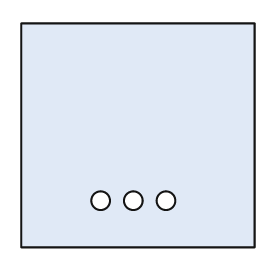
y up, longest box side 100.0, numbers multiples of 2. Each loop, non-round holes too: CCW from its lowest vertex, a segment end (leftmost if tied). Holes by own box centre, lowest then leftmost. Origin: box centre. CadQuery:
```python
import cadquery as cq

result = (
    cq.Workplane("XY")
    .moveTo(-50.0, -48.0)
    .lineTo(50.0, -48.0)
    .lineTo(50.0, 48.0)
    .lineTo(-50.0, 48.0)
    .close()
    .moveTo(-16.0, -28.0)
    .circle(4.0)
    .moveTo(-2.0, -28.0)
    .circle(4.0)
    .moveTo(12.0, -28.0)
    .circle(4.0)
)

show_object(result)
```